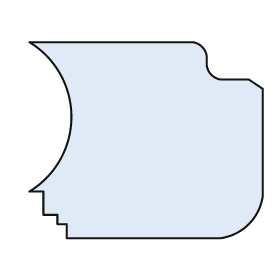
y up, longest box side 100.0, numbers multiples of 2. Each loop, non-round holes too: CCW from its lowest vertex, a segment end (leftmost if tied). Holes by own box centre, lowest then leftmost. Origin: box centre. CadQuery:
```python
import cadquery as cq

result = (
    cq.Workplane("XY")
    .moveTo(-34.0, -42.0)
    .lineTo(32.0, -42.0)
    .threePointArc((44.0, -36.0), (50.0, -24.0))
    .lineTo(50.0, 22.0)
    .lineTo(44.0, 26.0)
    .lineTo(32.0, 26.0)
    .threePointArc((28.0, 28.0), (26.0, 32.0))
    .lineTo(26.0, 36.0)
    .threePointArc((24.0, 40.0), (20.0, 42.0))
    .lineTo(-50.0, 42.0)
    .threePointArc((-32.0, 10.0), (-50.0, -22.0))
    .lineTo(-44.0, -22.0)
    .lineTo(-44.0, -32.0)
    .lineTo(-38.0, -32.0)
    .lineTo(-38.0, -36.0)
    .lineTo(-34.0, -36.0)
    .close()
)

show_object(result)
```